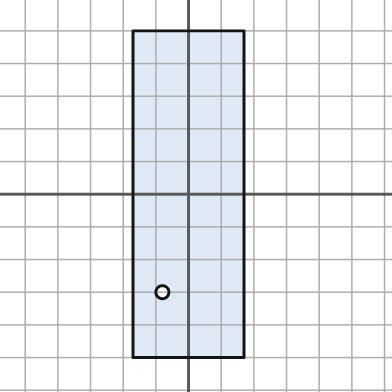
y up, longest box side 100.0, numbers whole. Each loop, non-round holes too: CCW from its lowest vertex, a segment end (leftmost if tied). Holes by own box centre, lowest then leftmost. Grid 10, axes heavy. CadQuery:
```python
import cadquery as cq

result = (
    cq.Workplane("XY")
    .moveTo(-17.0, -50.0)
    .lineTo(17.0, -50.0)
    .lineTo(17.0, 50.0)
    .lineTo(-17.0, 50.0)
    .close()
    .moveTo(-8.0, -30.0)
    .circle(2.0)
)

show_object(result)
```